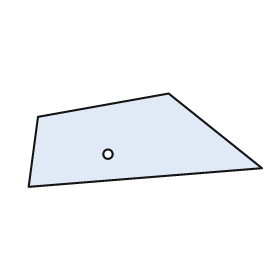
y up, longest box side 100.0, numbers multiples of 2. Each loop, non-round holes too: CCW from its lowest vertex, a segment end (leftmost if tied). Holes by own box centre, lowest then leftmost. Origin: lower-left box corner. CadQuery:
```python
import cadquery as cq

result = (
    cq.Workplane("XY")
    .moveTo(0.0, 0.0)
    .lineTo(100.0, 8.0)
    .lineTo(60.0, 40.0)
    .lineTo(4.0, 30.0)
    .close()
    .moveTo(34.0, 14.0)
    .circle(2.0)
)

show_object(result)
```